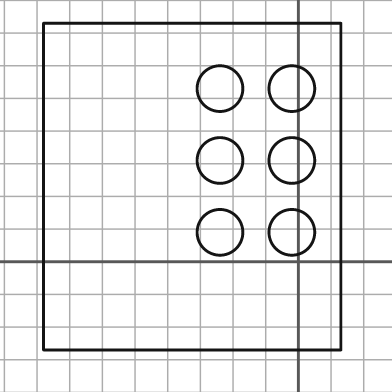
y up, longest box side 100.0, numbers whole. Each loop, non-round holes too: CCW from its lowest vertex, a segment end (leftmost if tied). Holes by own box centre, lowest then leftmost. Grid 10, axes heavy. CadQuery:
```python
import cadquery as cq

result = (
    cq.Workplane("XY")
    .moveTo(-78.0, -27.0)
    .lineTo(13.0, -27.0)
    .lineTo(13.0, 73.0)
    .lineTo(-78.0, 73.0)
    .close()
    .moveTo(-24.0, 9.0)
    .circle(7.0)
    .moveTo(-2.0, 9.0)
    .circle(7.0)
    .moveTo(-24.0, 31.0)
    .circle(7.0)
    .moveTo(-2.0, 31.0)
    .circle(7.0)
    .moveTo(-24.0, 53.0)
    .circle(7.0)
    .moveTo(-2.0, 53.0)
    .circle(7.0)
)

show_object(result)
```